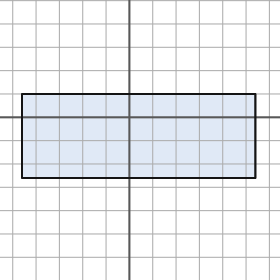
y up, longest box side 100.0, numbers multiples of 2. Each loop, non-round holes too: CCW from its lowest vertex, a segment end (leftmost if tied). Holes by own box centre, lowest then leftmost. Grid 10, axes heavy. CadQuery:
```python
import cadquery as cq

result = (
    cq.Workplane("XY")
    .moveTo(-46.0, -26.0)
    .lineTo(54.0, -26.0)
    .lineTo(54.0, 10.0)
    .lineTo(-46.0, 10.0)
    .close()
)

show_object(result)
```